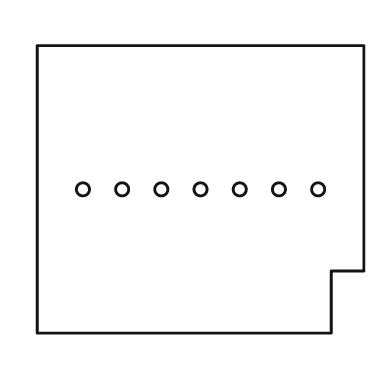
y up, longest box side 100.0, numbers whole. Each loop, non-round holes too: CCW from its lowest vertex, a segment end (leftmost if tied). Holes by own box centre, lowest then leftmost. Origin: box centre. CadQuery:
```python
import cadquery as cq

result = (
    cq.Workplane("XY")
    .moveTo(-50.0, -44.0)
    .lineTo(40.0, -44.0)
    .lineTo(40.0, -25.0)
    .lineTo(50.0, -25.0)
    .lineTo(50.0, 44.0)
    .lineTo(-50.0, 44.0)
    .close()
    .moveTo(-36.0, 0.0)
    .circle(2.0)
    .moveTo(-24.0, 0.0)
    .circle(2.0)
    .moveTo(-12.0, 0.0)
    .circle(2.0)
    .moveTo(0.0, 0.0)
    .circle(2.0)
    .moveTo(12.0, 0.0)
    .circle(2.0)
    .moveTo(24.0, 0.0)
    .circle(2.0)
    .moveTo(36.0, 0.0)
    .circle(2.0)
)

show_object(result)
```